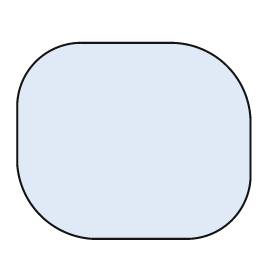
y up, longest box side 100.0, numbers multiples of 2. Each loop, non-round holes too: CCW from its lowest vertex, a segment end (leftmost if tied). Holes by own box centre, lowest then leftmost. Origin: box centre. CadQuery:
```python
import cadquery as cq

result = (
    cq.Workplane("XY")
    .moveTo(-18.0, -42.0)
    .lineTo(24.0, -42.0)
    .threePointArc((42.0, -34.0), (50.0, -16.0))
    .lineTo(50.0, 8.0)
    .threePointArc((40.0, 32.0), (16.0, 42.0))
    .lineTo(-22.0, 42.0)
    .threePointArc((-42.0, 34.0), (-50.0, 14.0))
    .lineTo(-50.0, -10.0)
    .threePointArc((-40.0, -32.0), (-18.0, -42.0))
    .close()
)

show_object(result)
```